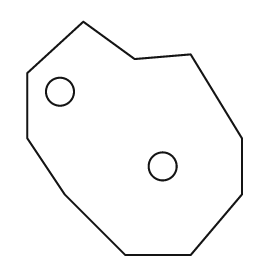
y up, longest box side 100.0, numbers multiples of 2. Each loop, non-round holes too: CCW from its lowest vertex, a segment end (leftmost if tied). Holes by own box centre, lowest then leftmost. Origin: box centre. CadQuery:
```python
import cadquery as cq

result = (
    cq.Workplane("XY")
    .moveTo(-4.0, -50.0)
    .lineTo(24.0, -50.0)
    .lineTo(46.0, -24.0)
    .lineTo(46.0, 0.0)
    .lineTo(24.0, 36.0)
    .lineTo(0.0, 34.0)
    .lineTo(-22.0, 50.0)
    .lineTo(-46.0, 28.0)
    .lineTo(-46.0, 0.0)
    .lineTo(-30.0, -24.0)
    .close()
    .moveTo(12.0, -12.0)
    .circle(6.0)
    .moveTo(-32.0, 20.0)
    .circle(6.0)
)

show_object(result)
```